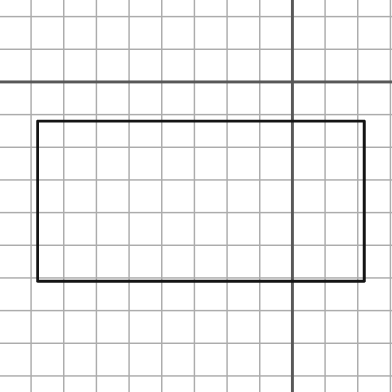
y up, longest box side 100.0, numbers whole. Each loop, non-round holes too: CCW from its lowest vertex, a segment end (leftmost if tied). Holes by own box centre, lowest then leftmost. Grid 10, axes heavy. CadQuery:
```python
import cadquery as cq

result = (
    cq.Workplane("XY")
    .moveTo(-78.0, -61.0)
    .lineTo(22.0, -61.0)
    .lineTo(22.0, -12.0)
    .lineTo(-78.0, -12.0)
    .close()
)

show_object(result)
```